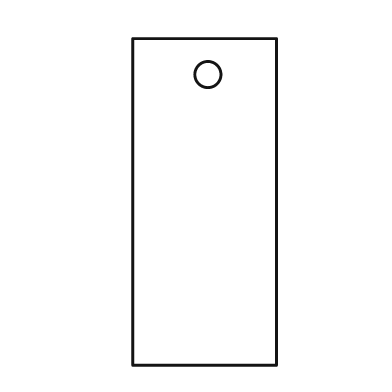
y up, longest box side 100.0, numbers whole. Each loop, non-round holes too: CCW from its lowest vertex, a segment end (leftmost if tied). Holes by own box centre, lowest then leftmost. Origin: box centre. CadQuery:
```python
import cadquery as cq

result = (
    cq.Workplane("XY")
    .moveTo(-22.0, -50.0)
    .lineTo(22.0, -50.0)
    .lineTo(22.0, 50.0)
    .lineTo(-22.0, 50.0)
    .close()
    .moveTo(1.0, 39.0)
    .circle(4.0)
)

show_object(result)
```